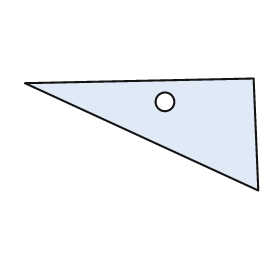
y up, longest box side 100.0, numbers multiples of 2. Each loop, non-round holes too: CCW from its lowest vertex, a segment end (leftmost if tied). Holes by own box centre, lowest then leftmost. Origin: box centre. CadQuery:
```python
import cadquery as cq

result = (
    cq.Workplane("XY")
    .moveTo(50.0, -24.0)
    .lineTo(48.0, 24.0)
    .lineTo(-50.0, 22.0)
    .close()
    .moveTo(10.0, 14.0)
    .circle(4.0)
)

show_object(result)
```